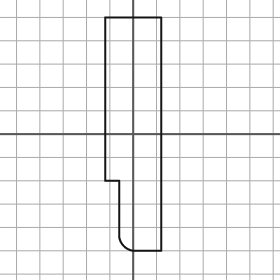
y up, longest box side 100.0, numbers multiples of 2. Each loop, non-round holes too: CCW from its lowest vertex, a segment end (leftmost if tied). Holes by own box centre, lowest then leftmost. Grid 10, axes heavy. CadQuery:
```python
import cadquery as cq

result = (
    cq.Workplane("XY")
    .moveTo(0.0, -50.0)
    .lineTo(12.0, -50.0)
    .lineTo(12.0, 50.0)
    .lineTo(-12.0, 50.0)
    .lineTo(-12.0, -20.0)
    .lineTo(-6.0, -20.0)
    .lineTo(-6.0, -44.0)
    .threePointArc((-4.0, -48.0), (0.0, -50.0))
    .close()
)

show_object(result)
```